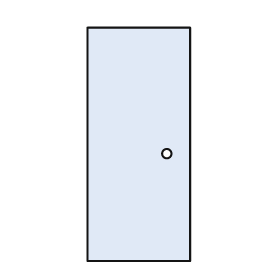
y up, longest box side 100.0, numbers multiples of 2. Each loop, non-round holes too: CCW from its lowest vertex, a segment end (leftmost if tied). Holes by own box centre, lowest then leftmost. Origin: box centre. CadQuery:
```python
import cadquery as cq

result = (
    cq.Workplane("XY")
    .moveTo(-22.0, -50.0)
    .lineTo(22.0, -50.0)
    .lineTo(22.0, 50.0)
    .lineTo(-22.0, 50.0)
    .close()
    .moveTo(12.0, -4.0)
    .circle(2.0)
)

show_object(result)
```